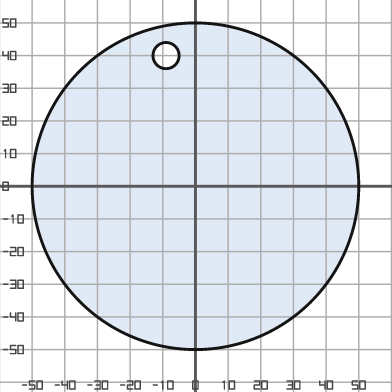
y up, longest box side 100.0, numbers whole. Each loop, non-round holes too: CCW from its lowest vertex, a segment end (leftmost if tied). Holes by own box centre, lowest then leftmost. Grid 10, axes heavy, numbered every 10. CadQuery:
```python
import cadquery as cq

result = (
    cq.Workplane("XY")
    .moveTo(0.0, 0.0)
    .circle(50.0)
    .moveTo(-9.0, 40.0)
    .circle(4.0)
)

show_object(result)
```